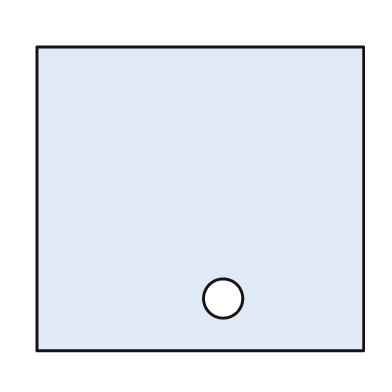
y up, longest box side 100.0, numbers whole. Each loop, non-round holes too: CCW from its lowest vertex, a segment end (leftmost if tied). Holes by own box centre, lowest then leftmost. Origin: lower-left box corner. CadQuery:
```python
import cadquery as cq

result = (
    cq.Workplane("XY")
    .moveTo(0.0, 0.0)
    .lineTo(100.0, 0.0)
    .lineTo(100.0, 93.0)
    .lineTo(0.0, 93.0)
    .close()
    .moveTo(57.0, 16.0)
    .circle(6.0)
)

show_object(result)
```